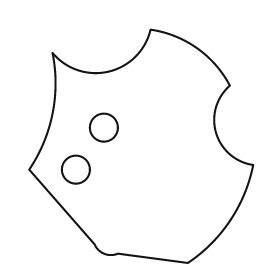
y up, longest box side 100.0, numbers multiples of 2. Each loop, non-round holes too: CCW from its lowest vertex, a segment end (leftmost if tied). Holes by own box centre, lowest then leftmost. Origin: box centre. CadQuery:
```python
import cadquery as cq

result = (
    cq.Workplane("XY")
    .moveTo(20.0, -50.0)
    .threePointArc((38.0, -32.0), (48.0, -8.0))
    .threePointArc((32.0, 6.0), (38.0, 26.0))
    .threePointArc((24.0, 42.0), (4.0, 50.0))
    .threePointArc((-14.0, 32.0), (-38.0, 40.0))
    .threePointArc((-38.0, 14.0), (-48.0, -10.0))
    .lineTo(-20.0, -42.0)
    .threePointArc((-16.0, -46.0), (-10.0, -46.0))
    .close()
    .moveTo(-28.0, -10.0)
    .circle(6.0)
    .moveTo(-16.0, 8.0)
    .circle(6.0)
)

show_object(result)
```